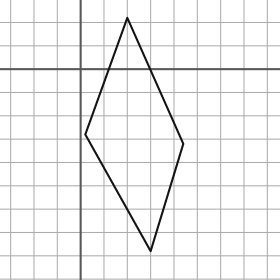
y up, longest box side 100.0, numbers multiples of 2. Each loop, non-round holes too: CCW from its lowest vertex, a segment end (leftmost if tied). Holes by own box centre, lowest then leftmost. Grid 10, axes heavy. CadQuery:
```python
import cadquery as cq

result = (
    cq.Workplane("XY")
    .moveTo(30.0, -78.0)
    .lineTo(44.0, -32.0)
    .lineTo(20.0, 22.0)
    .lineTo(2.0, -28.0)
    .close()
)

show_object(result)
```